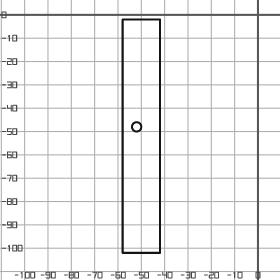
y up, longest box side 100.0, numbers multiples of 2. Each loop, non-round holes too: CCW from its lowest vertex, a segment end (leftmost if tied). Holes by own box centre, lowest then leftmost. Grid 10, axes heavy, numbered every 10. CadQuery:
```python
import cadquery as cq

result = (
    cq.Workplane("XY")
    .moveTo(-58.0, -102.0)
    .lineTo(-42.0, -102.0)
    .lineTo(-42.0, -2.0)
    .lineTo(-58.0, -2.0)
    .close()
    .moveTo(-52.0, -48.0)
    .circle(2.0)
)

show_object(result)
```